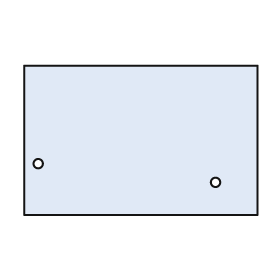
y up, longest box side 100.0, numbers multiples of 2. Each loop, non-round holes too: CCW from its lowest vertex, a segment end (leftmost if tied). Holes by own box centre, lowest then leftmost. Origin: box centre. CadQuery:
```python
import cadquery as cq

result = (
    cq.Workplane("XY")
    .moveTo(-50.0, -32.0)
    .lineTo(50.0, -32.0)
    .lineTo(50.0, 32.0)
    .lineTo(-50.0, 32.0)
    .close()
    .moveTo(32.0, -18.0)
    .circle(2.0)
    .moveTo(-44.0, -10.0)
    .circle(2.0)
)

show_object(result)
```